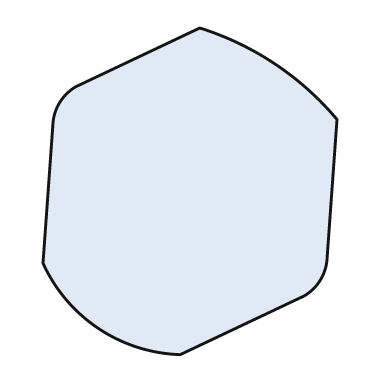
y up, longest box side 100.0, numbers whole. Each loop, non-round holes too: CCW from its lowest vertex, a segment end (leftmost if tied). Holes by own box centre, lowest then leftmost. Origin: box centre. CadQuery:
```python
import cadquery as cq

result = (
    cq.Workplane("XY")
    .moveTo(-3.0, -50.0)
    .lineTo(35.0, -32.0)
    .threePointArc((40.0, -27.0), (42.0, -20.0))
    .lineTo(45.0, 22.0)
    .threePointArc((26.0, 39.0), (3.0, 50.0))
    .lineTo(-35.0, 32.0)
    .threePointArc((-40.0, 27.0), (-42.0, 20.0))
    .lineTo(-45.0, -22.0)
    .threePointArc((-28.0, -42.0), (-3.0, -50.0))
    .close()
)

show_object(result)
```